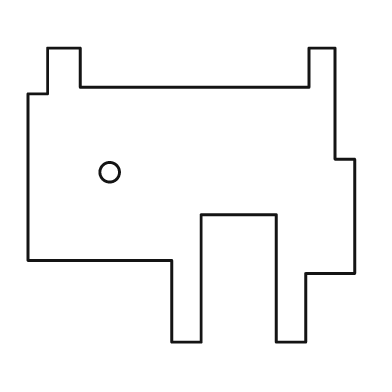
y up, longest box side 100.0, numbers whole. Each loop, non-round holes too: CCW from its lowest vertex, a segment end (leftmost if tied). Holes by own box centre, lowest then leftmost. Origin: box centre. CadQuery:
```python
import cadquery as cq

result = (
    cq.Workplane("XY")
    .moveTo(-6.0, -45.0)
    .lineTo(3.0, -45.0)
    .lineTo(3.0, -6.0)
    .lineTo(26.0, -6.0)
    .lineTo(26.0, -45.0)
    .lineTo(35.0, -45.0)
    .lineTo(35.0, -24.0)
    .lineTo(50.0, -24.0)
    .lineTo(50.0, 11.0)
    .lineTo(44.0, 11.0)
    .lineTo(44.0, 45.0)
    .lineTo(36.0, 45.0)
    .lineTo(36.0, 33.0)
    .lineTo(-34.0, 33.0)
    .lineTo(-34.0, 45.0)
    .lineTo(-44.0, 45.0)
    .lineTo(-44.0, 31.0)
    .lineTo(-50.0, 31.0)
    .lineTo(-50.0, -20.0)
    .lineTo(-6.0, -20.0)
    .close()
    .moveTo(-25.0, 7.0)
    .circle(3.0)
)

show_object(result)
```